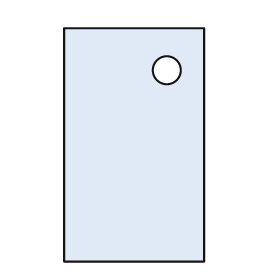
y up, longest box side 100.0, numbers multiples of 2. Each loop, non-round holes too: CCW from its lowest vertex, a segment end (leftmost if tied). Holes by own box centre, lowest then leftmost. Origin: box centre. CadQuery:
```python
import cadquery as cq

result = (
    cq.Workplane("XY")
    .moveTo(-30.0, -50.0)
    .lineTo(30.0, -50.0)
    .lineTo(30.0, 50.0)
    .lineTo(-30.0, 50.0)
    .close()
    .moveTo(14.0, 32.0)
    .circle(6.0)
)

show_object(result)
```